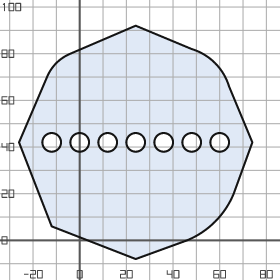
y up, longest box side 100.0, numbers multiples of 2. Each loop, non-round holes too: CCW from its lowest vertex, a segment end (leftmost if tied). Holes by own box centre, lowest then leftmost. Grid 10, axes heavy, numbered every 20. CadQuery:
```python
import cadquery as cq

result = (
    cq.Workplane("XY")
    .moveTo(24.0, -8.0)
    .lineTo(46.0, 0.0)
    .threePointArc((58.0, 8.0), (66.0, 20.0))
    .lineTo(74.0, 42.0)
    .lineTo(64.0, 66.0)
    .threePointArc((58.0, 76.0), (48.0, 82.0))
    .lineTo(24.0, 92.0)
    .lineTo(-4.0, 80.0)
    .threePointArc((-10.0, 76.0), (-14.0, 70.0))
    .lineTo(-26.0, 42.0)
    .lineTo(-12.0, 6.0)
    .close()
    .moveTo(-12.0, 42.0)
    .circle(4.0)
    .moveTo(0.0, 42.0)
    .circle(4.0)
    .moveTo(12.0, 42.0)
    .circle(4.0)
    .moveTo(24.0, 42.0)
    .circle(4.0)
    .moveTo(36.0, 42.0)
    .circle(4.0)
    .moveTo(48.0, 42.0)
    .circle(4.0)
    .moveTo(60.0, 42.0)
    .circle(4.0)
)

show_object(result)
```